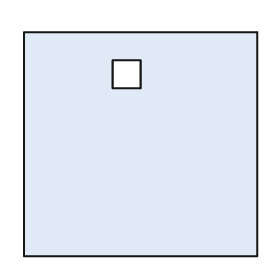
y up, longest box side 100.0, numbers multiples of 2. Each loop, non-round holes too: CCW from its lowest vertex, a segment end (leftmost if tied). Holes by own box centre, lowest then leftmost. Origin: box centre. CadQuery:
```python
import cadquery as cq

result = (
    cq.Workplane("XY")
    .moveTo(-50.0, -48.0)
    .lineTo(50.0, -48.0)
    .lineTo(50.0, 48.0)
    .lineTo(-50.0, 48.0)
    .close()
    .moveTo(-12.0, 24.0)
    .lineTo(0.0, 24.0)
    .lineTo(0.0, 36.0)
    .lineTo(-12.0, 36.0)
    .close()
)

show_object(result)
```